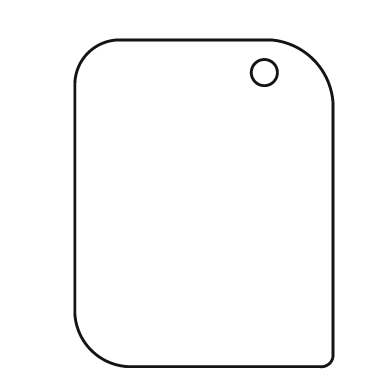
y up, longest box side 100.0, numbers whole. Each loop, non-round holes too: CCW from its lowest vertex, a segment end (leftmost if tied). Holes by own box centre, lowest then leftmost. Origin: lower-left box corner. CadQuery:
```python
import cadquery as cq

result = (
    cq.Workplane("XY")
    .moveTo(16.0, 0.0)
    .lineTo(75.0, 0.0)
    .threePointArc((78.0, 1.0), (79.0, 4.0))
    .lineTo(79.0, 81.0)
    .threePointArc((73.0, 94.0), (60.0, 100.0))
    .lineTo(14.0, 100.0)
    .threePointArc((4.0, 96.0), (0.0, 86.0))
    .lineTo(0.0, 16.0)
    .threePointArc((5.0, 5.0), (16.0, 0.0))
    .close()
    .moveTo(58.0, 90.0)
    .circle(4.0)
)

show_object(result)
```